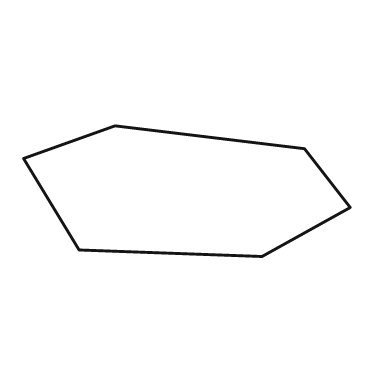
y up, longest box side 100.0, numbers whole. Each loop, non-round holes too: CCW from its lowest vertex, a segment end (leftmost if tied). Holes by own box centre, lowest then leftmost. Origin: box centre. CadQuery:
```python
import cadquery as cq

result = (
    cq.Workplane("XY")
    .moveTo(23.0, -20.0)
    .lineTo(50.0, -5.0)
    .lineTo(36.0, 13.0)
    .lineTo(-22.0, 20.0)
    .lineTo(-50.0, 10.0)
    .lineTo(-33.0, -18.0)
    .close()
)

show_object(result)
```